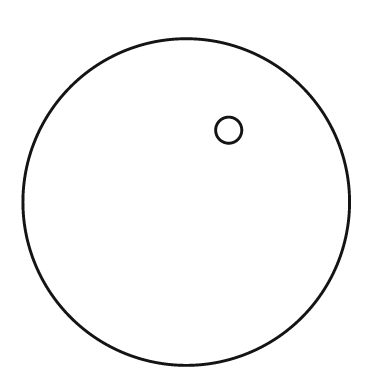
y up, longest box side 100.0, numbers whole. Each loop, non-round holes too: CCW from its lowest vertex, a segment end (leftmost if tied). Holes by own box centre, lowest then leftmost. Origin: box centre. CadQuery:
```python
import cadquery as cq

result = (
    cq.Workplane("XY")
    .moveTo(0.0, 0.0)
    .circle(50.0)
    .moveTo(13.0, 22.0)
    .circle(4.0)
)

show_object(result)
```